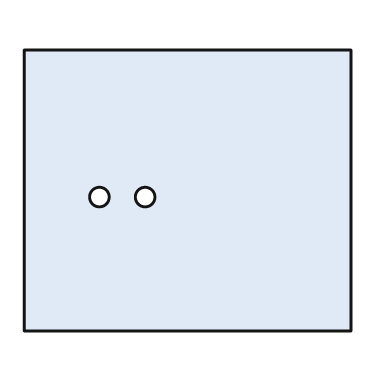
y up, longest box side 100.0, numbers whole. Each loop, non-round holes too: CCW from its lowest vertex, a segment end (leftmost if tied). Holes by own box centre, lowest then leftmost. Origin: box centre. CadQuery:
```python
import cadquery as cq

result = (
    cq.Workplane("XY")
    .moveTo(-50.0, -43.0)
    .lineTo(50.0, -43.0)
    .lineTo(50.0, 43.0)
    .lineTo(-50.0, 43.0)
    .close()
    .moveTo(-27.0, -2.0)
    .circle(3.0)
    .moveTo(-13.0, -2.0)
    .circle(3.0)
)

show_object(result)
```